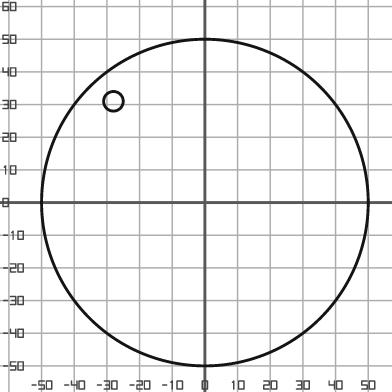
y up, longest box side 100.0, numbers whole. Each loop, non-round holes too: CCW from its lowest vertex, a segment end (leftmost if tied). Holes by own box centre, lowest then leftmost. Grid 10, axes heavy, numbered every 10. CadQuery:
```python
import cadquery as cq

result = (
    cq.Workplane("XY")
    .moveTo(0.0, 0.0)
    .circle(50.0)
    .moveTo(-28.0, 31.0)
    .circle(3.0)
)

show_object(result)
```